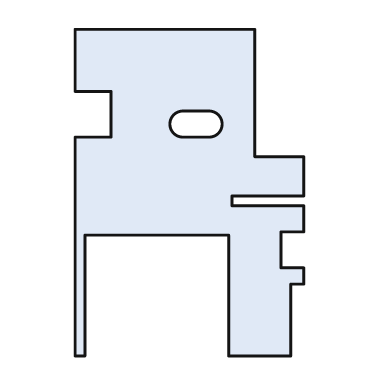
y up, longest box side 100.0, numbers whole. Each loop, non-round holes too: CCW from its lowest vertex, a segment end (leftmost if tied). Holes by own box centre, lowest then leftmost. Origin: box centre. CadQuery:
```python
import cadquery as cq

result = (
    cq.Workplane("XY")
    .moveTo(-35.0, -50.0)
    .lineTo(-32.0, -50.0)
    .lineTo(-32.0, -13.0)
    .lineTo(12.0, -13.0)
    .lineTo(12.0, -50.0)
    .lineTo(31.0, -50.0)
    .lineTo(31.0, -28.0)
    .lineTo(35.0, -28.0)
    .lineTo(35.0, -23.0)
    .lineTo(28.0, -23.0)
    .lineTo(28.0, -12.0)
    .lineTo(35.0, -12.0)
    .lineTo(35.0, -4.0)
    .lineTo(13.0, -4.0)
    .lineTo(13.0, -1.0)
    .lineTo(35.0, -1.0)
    .lineTo(35.0, 11.0)
    .lineTo(20.0, 11.0)
    .lineTo(20.0, 50.0)
    .lineTo(-35.0, 50.0)
    .lineTo(-35.0, 31.0)
    .lineTo(-24.0, 31.0)
    .lineTo(-24.0, 17.0)
    .lineTo(-35.0, 17.0)
    .close()
    .moveTo(-2.0, 17.0)
    .lineTo(6.0, 17.0)
    .threePointArc((10.0, 21.0), (6.0, 25.0))
    .lineTo(-2.0, 25.0)
    .threePointArc((-6.0, 21.0), (-2.0, 17.0))
    .close()
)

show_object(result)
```